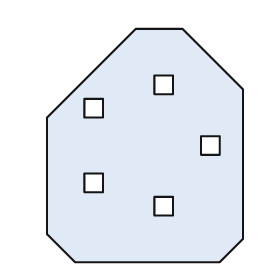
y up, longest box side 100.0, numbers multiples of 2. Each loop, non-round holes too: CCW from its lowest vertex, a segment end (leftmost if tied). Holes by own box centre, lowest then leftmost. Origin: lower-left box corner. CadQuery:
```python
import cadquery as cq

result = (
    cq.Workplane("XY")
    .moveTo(12.0, 0.0)
    .lineTo(74.0, 0.0)
    .lineTo(84.0, 10.0)
    .lineTo(84.0, 74.0)
    .lineTo(58.0, 100.0)
    .lineTo(38.0, 100.0)
    .lineTo(0.0, 62.0)
    .lineTo(0.0, 12.0)
    .close()
    .moveTo(46.0, 20.0)
    .lineTo(54.0, 20.0)
    .lineTo(54.0, 28.0)
    .lineTo(46.0, 28.0)
    .close()
    .moveTo(16.0, 30.0)
    .lineTo(24.0, 30.0)
    .lineTo(24.0, 38.0)
    .lineTo(16.0, 38.0)
    .close()
    .moveTo(66.0, 46.0)
    .lineTo(74.0, 46.0)
    .lineTo(74.0, 54.0)
    .lineTo(66.0, 54.0)
    .close()
    .moveTo(16.0, 62.0)
    .lineTo(24.0, 62.0)
    .lineTo(24.0, 70.0)
    .lineTo(16.0, 70.0)
    .close()
    .moveTo(46.0, 72.0)
    .lineTo(54.0, 72.0)
    .lineTo(54.0, 80.0)
    .lineTo(46.0, 80.0)
    .close()
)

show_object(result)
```